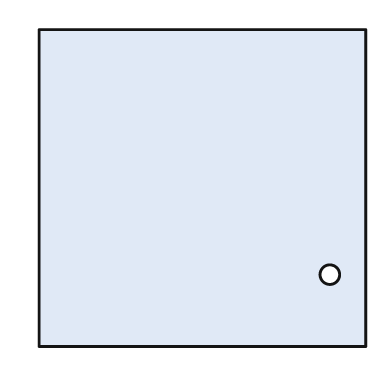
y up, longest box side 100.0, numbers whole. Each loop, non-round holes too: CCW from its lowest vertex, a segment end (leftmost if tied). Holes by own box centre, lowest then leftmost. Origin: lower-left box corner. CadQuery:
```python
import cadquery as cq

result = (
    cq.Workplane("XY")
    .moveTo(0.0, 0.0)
    .lineTo(100.0, 0.0)
    .lineTo(100.0, 97.0)
    .lineTo(0.0, 97.0)
    .close()
    .moveTo(89.0, 22.0)
    .circle(3.0)
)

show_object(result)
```